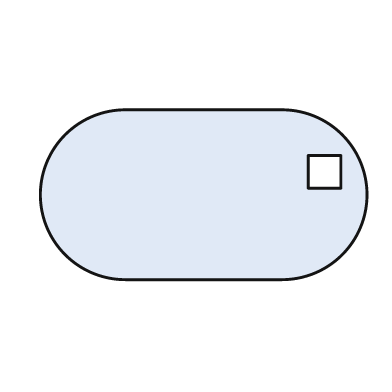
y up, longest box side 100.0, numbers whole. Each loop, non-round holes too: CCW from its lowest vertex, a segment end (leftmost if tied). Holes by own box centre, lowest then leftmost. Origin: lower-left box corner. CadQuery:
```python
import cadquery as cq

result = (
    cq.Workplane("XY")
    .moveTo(26.0, 0.0)
    .lineTo(74.0, 0.0)
    .threePointArc((100.0, 26.0), (74.0, 52.0))
    .lineTo(26.0, 52.0)
    .threePointArc((0.0, 26.0), (26.0, 0.0))
    .close()
    .moveTo(82.0, 28.0)
    .lineTo(92.0, 28.0)
    .lineTo(92.0, 38.0)
    .lineTo(82.0, 38.0)
    .close()
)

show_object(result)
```